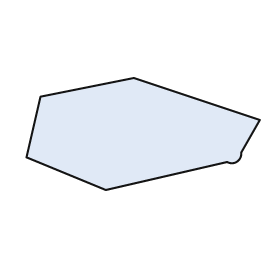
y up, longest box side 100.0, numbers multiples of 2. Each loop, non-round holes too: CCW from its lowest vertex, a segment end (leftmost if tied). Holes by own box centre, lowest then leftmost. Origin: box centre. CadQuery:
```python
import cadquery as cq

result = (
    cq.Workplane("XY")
    .moveTo(-16.0, -24.0)
    .lineTo(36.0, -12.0)
    .threePointArc((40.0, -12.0), (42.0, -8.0))
    .lineTo(50.0, 6.0)
    .lineTo(-4.0, 24.0)
    .lineTo(-44.0, 16.0)
    .lineTo(-50.0, -10.0)
    .close()
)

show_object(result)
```